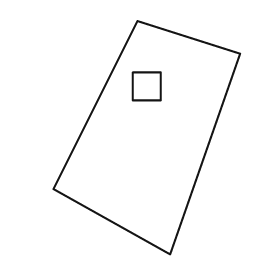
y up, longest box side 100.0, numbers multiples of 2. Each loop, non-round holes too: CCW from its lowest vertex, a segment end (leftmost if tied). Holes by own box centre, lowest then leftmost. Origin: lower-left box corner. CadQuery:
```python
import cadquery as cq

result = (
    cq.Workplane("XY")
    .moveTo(50.0, 0.0)
    .lineTo(80.0, 86.0)
    .lineTo(36.0, 100.0)
    .lineTo(0.0, 28.0)
    .close()
    .moveTo(34.0, 66.0)
    .lineTo(46.0, 66.0)
    .lineTo(46.0, 78.0)
    .lineTo(34.0, 78.0)
    .close()
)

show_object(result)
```